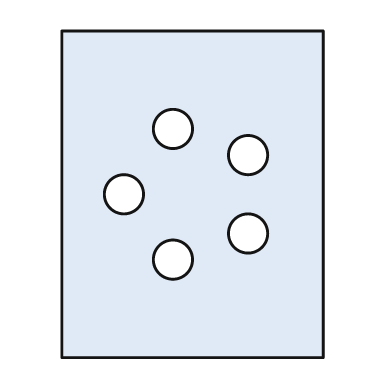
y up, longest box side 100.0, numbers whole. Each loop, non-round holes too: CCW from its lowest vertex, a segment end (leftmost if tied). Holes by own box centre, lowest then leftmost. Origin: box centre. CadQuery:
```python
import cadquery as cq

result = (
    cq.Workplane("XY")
    .moveTo(-40.0, -50.0)
    .lineTo(40.0, -50.0)
    .lineTo(40.0, 50.0)
    .lineTo(-40.0, 50.0)
    .close()
    .moveTo(-6.0, -20.0)
    .circle(6.0)
    .moveTo(17.0, -12.0)
    .circle(6.0)
    .moveTo(-21.0, 0.0)
    .circle(6.0)
    .moveTo(17.0, 12.0)
    .circle(6.0)
    .moveTo(-6.0, 20.0)
    .circle(6.0)
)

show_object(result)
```